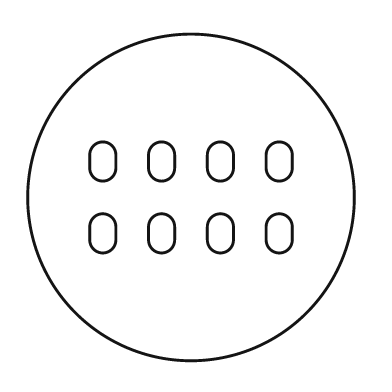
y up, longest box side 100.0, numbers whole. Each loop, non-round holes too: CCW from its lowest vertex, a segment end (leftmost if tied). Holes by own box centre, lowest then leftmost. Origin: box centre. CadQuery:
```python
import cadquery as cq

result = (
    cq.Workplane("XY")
    .moveTo(0.0, 0.0)
    .circle(50.0)
    .moveTo(-31.0, -13.0)
    .threePointArc((-27.0, -17.0), (-23.0, -13.0))
    .lineTo(-23.0, -9.0)
    .threePointArc((-27.0, -5.0), (-31.0, -9.0))
    .close()
    .moveTo(-13.0, -13.0)
    .threePointArc((-9.0, -17.0), (-5.0, -13.0))
    .lineTo(-5.0, -9.0)
    .threePointArc((-9.0, -5.0), (-13.0, -9.0))
    .close()
    .moveTo(5.0, -13.0)
    .threePointArc((9.0, -17.0), (13.0, -13.0))
    .lineTo(13.0, -9.0)
    .threePointArc((9.0, -5.0), (5.0, -9.0))
    .close()
    .moveTo(23.0, -13.0)
    .threePointArc((27.0, -17.0), (31.0, -13.0))
    .lineTo(31.0, -9.0)
    .threePointArc((27.0, -5.0), (23.0, -9.0))
    .close()
    .moveTo(-31.0, 9.0)
    .threePointArc((-27.0, 5.0), (-23.0, 9.0))
    .lineTo(-23.0, 13.0)
    .threePointArc((-27.0, 17.0), (-31.0, 13.0))
    .close()
    .moveTo(-13.0, 9.0)
    .threePointArc((-9.0, 5.0), (-5.0, 9.0))
    .lineTo(-5.0, 13.0)
    .threePointArc((-9.0, 17.0), (-13.0, 13.0))
    .close()
    .moveTo(5.0, 9.0)
    .threePointArc((9.0, 5.0), (13.0, 9.0))
    .lineTo(13.0, 13.0)
    .threePointArc((9.0, 17.0), (5.0, 13.0))
    .close()
    .moveTo(23.0, 9.0)
    .threePointArc((27.0, 5.0), (31.0, 9.0))
    .lineTo(31.0, 13.0)
    .threePointArc((27.0, 17.0), (23.0, 13.0))
    .close()
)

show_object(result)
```